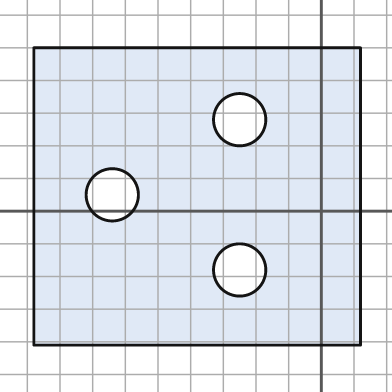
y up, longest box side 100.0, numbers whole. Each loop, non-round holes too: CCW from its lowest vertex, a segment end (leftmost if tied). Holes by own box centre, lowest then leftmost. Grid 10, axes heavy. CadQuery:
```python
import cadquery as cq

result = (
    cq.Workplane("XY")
    .moveTo(-88.0, -41.0)
    .lineTo(12.0, -41.0)
    .lineTo(12.0, 50.0)
    .lineTo(-88.0, 50.0)
    .close()
    .moveTo(-25.0, -18.0)
    .circle(8.0)
    .moveTo(-64.0, 5.0)
    .circle(8.0)
    .moveTo(-25.0, 28.0)
    .circle(8.0)
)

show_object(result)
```